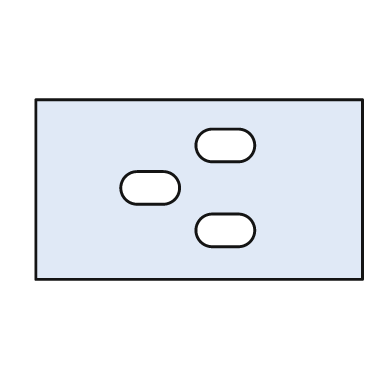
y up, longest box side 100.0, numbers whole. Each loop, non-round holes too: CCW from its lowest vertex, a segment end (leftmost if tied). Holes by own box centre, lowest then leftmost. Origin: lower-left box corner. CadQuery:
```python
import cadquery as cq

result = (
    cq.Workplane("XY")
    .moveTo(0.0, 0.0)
    .lineTo(100.0, 0.0)
    .lineTo(100.0, 55.0)
    .lineTo(0.0, 55.0)
    .close()
    .moveTo(54.0, 10.0)
    .lineTo(62.0, 10.0)
    .threePointArc((67.0, 15.0), (62.0, 20.0))
    .lineTo(54.0, 20.0)
    .threePointArc((49.0, 15.0), (54.0, 10.0))
    .close()
    .moveTo(31.0, 23.0)
    .lineTo(39.0, 23.0)
    .threePointArc((44.0, 28.0), (39.0, 33.0))
    .lineTo(31.0, 33.0)
    .threePointArc((26.0, 28.0), (31.0, 23.0))
    .close()
    .moveTo(54.0, 36.0)
    .lineTo(62.0, 36.0)
    .threePointArc((67.0, 41.0), (62.0, 46.0))
    .lineTo(54.0, 46.0)
    .threePointArc((49.0, 41.0), (54.0, 36.0))
    .close()
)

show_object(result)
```